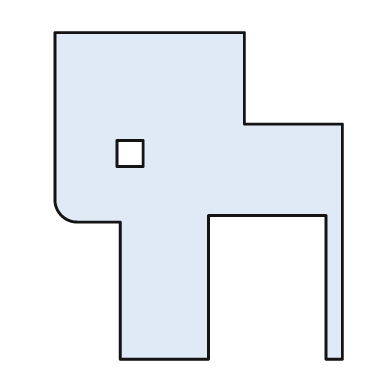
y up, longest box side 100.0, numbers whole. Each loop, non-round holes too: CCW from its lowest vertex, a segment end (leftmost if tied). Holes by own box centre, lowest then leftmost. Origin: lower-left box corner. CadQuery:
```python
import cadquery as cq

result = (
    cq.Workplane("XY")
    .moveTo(20.0, 0.0)
    .lineTo(47.0, 0.0)
    .lineTo(47.0, 44.0)
    .lineTo(83.0, 44.0)
    .lineTo(83.0, 0.0)
    .lineTo(88.0, 0.0)
    .lineTo(88.0, 72.0)
    .lineTo(58.0, 72.0)
    .lineTo(58.0, 100.0)
    .lineTo(0.0, 100.0)
    .lineTo(0.0, 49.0)
    .threePointArc((2.0, 44.0), (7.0, 42.0))
    .lineTo(20.0, 42.0)
    .close()
    .moveTo(19.0, 59.0)
    .lineTo(27.0, 59.0)
    .lineTo(27.0, 67.0)
    .lineTo(19.0, 67.0)
    .close()
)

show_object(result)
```